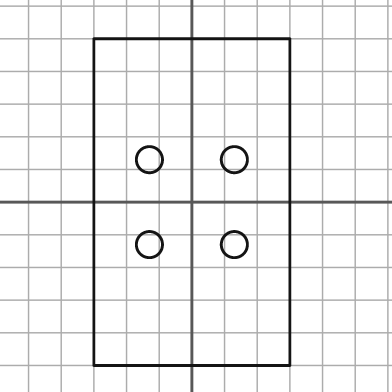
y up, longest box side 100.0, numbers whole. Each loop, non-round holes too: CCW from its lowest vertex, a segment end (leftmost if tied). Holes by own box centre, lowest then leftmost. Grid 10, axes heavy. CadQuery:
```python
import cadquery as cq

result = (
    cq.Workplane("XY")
    .moveTo(-30.0, -50.0)
    .lineTo(30.0, -50.0)
    .lineTo(30.0, 50.0)
    .lineTo(-30.0, 50.0)
    .close()
    .moveTo(-13.0, -13.0)
    .circle(4.0)
    .moveTo(13.0, -13.0)
    .circle(4.0)
    .moveTo(-13.0, 13.0)
    .circle(4.0)
    .moveTo(13.0, 13.0)
    .circle(4.0)
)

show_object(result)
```